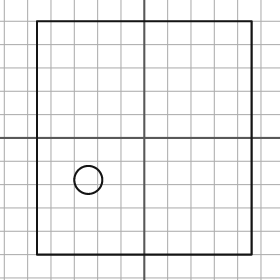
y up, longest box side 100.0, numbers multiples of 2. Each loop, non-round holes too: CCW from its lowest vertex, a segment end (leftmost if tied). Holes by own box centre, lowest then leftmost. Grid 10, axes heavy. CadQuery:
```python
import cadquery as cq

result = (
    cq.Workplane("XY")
    .moveTo(-46.0, -50.0)
    .lineTo(46.0, -50.0)
    .lineTo(46.0, 50.0)
    .lineTo(-46.0, 50.0)
    .close()
    .moveTo(-24.0, -18.0)
    .circle(6.0)
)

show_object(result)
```